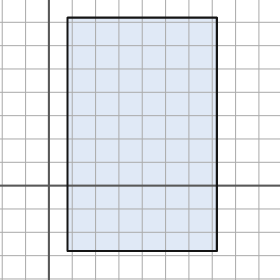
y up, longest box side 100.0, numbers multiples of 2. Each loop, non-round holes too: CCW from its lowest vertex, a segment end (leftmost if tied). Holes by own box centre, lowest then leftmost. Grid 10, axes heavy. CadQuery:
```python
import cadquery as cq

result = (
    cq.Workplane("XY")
    .moveTo(8.0, -28.0)
    .lineTo(72.0, -28.0)
    .lineTo(72.0, 72.0)
    .lineTo(8.0, 72.0)
    .close()
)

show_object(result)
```